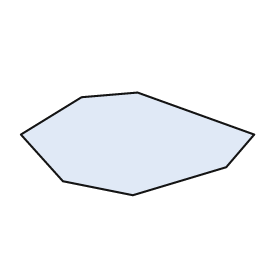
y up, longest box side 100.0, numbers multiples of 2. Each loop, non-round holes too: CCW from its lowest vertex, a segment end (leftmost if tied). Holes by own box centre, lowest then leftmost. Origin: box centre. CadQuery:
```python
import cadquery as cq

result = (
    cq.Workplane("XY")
    .moveTo(-2.0, -22.0)
    .lineTo(38.0, -10.0)
    .lineTo(50.0, 4.0)
    .lineTo(0.0, 22.0)
    .lineTo(-24.0, 20.0)
    .lineTo(-50.0, 4.0)
    .lineTo(-32.0, -16.0)
    .close()
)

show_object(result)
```